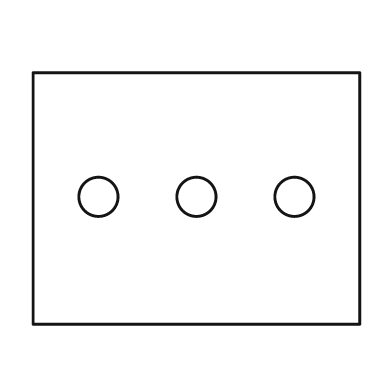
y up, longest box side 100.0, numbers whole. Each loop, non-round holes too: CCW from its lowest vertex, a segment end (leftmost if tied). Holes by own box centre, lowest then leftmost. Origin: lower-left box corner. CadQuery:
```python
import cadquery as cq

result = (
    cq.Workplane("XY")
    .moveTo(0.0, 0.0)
    .lineTo(100.0, 0.0)
    .lineTo(100.0, 77.0)
    .lineTo(0.0, 77.0)
    .close()
    .moveTo(20.0, 39.0)
    .circle(6.0)
    .moveTo(50.0, 39.0)
    .circle(6.0)
    .moveTo(80.0, 39.0)
    .circle(6.0)
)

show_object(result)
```